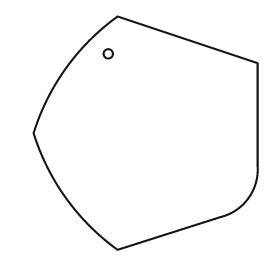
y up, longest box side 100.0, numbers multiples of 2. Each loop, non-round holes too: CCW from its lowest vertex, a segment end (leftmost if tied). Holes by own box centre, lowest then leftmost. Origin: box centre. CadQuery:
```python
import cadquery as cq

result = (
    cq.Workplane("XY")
    .moveTo(-12.0, -50.0)
    .lineTo(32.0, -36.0)
    .threePointArc((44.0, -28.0), (48.0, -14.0))
    .lineTo(48.0, 30.0)
    .lineTo(-12.0, 50.0)
    .threePointArc((-34.0, 28.0), (-48.0, 0.0))
    .threePointArc((-34.0, -28.0), (-12.0, -50.0))
    .close()
    .moveTo(-16.0, 34.0)
    .circle(2.0)
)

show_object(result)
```